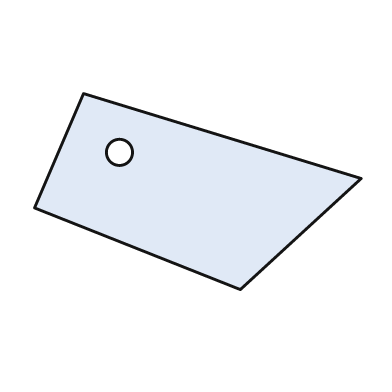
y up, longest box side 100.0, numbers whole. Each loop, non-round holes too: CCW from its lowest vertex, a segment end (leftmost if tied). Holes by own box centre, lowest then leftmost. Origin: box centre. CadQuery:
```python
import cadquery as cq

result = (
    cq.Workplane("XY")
    .moveTo(13.0, -30.0)
    .lineTo(50.0, 4.0)
    .lineTo(-35.0, 30.0)
    .lineTo(-50.0, -5.0)
    .close()
    .moveTo(-24.0, 12.0)
    .circle(4.0)
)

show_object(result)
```